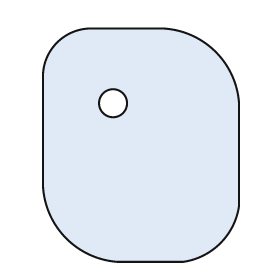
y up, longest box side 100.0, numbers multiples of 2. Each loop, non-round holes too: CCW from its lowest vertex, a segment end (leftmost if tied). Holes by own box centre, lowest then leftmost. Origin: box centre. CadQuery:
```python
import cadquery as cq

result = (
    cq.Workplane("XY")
    .moveTo(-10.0, -50.0)
    .lineTo(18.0, -50.0)
    .threePointArc((34.0, -42.0), (42.0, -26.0))
    .lineTo(42.0, 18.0)
    .threePointArc((32.0, 40.0), (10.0, 50.0))
    .lineTo(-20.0, 50.0)
    .threePointArc((-36.0, 44.0), (-42.0, 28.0))
    .lineTo(-42.0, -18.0)
    .threePointArc((-32.0, -40.0), (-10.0, -50.0))
    .close()
    .moveTo(-12.0, 18.0)
    .circle(6.0)
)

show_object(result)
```